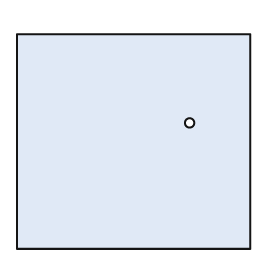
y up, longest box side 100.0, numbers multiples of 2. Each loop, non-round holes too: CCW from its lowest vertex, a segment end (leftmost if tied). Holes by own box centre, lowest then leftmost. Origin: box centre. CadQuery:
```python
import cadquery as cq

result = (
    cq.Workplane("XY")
    .moveTo(-50.0, -46.0)
    .lineTo(50.0, -46.0)
    .lineTo(50.0, 46.0)
    .lineTo(-50.0, 46.0)
    .close()
    .moveTo(24.0, 8.0)
    .circle(2.0)
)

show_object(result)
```